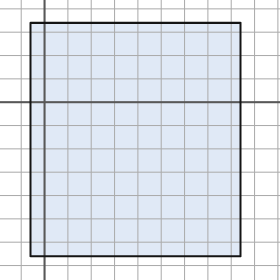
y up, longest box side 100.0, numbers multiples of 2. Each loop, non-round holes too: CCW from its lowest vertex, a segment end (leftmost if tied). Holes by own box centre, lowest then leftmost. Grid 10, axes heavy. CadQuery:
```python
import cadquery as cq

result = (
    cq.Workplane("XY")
    .moveTo(-6.0, -66.0)
    .lineTo(84.0, -66.0)
    .lineTo(84.0, 34.0)
    .lineTo(-6.0, 34.0)
    .close()
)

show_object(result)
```